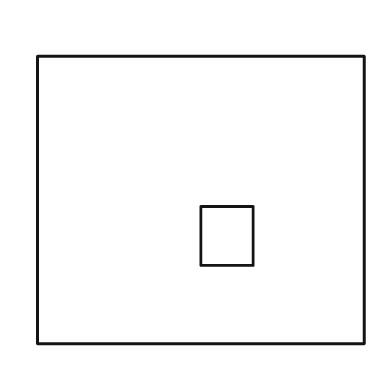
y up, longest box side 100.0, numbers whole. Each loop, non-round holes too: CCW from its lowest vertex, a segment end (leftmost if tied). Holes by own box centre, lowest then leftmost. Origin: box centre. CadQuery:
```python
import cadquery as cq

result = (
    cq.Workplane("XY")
    .moveTo(-50.0, -44.0)
    .lineTo(50.0, -44.0)
    .lineTo(50.0, 44.0)
    .lineTo(-50.0, 44.0)
    .close()
    .moveTo(0.0, -20.0)
    .lineTo(16.0, -20.0)
    .lineTo(16.0, -2.0)
    .lineTo(0.0, -2.0)
    .close()
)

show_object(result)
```